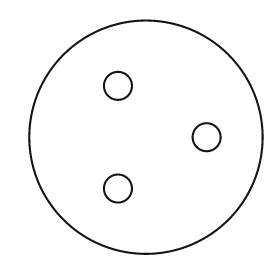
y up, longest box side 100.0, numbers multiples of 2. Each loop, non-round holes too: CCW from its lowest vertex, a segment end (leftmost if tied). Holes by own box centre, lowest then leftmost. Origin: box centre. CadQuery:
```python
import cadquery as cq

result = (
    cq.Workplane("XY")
    .moveTo(0.0, 0.0)
    .circle(50.0)
    .moveTo(-12.0, -22.0)
    .circle(6.0)
    .moveTo(26.0, 0.0)
    .circle(6.0)
    .moveTo(-12.0, 22.0)
    .circle(6.0)
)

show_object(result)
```